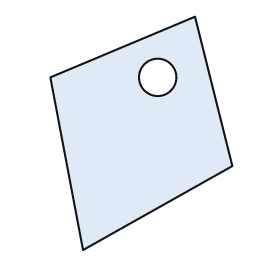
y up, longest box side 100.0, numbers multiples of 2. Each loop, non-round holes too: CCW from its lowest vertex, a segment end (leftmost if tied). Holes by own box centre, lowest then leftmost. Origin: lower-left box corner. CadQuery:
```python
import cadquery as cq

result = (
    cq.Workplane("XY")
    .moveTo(14.0, 0.0)
    .lineTo(78.0, 36.0)
    .lineTo(62.0, 100.0)
    .lineTo(0.0, 74.0)
    .close()
    .moveTo(46.0, 74.0)
    .circle(8.0)
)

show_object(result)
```